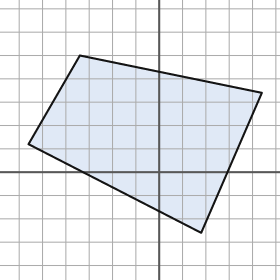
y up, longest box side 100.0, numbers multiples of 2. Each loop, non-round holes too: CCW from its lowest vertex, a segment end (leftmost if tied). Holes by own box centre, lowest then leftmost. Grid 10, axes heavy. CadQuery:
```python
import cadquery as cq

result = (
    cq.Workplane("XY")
    .moveTo(18.0, -26.0)
    .lineTo(44.0, 34.0)
    .lineTo(-34.0, 50.0)
    .lineTo(-56.0, 12.0)
    .close()
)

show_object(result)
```